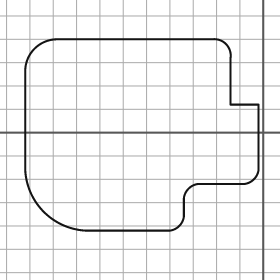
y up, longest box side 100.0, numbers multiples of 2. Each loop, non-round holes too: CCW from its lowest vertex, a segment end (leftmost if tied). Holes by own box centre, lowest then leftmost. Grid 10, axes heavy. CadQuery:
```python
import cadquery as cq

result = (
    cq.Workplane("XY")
    .moveTo(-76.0, -42.0)
    .lineTo(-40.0, -42.0)
    .threePointArc((-36.0, -40.0), (-34.0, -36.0))
    .lineTo(-34.0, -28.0)
    .threePointArc((-32.0, -24.0), (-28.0, -22.0))
    .lineTo(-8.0, -22.0)
    .threePointArc((-4.0, -20.0), (-2.0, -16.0))
    .lineTo(-2.0, 12.0)
    .lineTo(-14.0, 12.0)
    .lineTo(-14.0, 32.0)
    .threePointArc((-16.0, 38.0), (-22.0, 40.0))
    .lineTo(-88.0, 40.0)
    .threePointArc((-98.0, 36.0), (-102.0, 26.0))
    .lineTo(-102.0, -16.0)
    .threePointArc((-94.0, -34.0), (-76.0, -42.0))
    .close()
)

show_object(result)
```